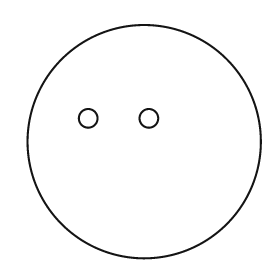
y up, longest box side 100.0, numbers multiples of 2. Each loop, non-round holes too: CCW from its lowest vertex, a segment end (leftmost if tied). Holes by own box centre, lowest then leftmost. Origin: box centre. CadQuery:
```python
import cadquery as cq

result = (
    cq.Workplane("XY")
    .moveTo(0.0, 0.0)
    .circle(50.0)
    .moveTo(-24.0, 10.0)
    .circle(4.0)
    .moveTo(2.0, 10.0)
    .circle(4.0)
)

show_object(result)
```